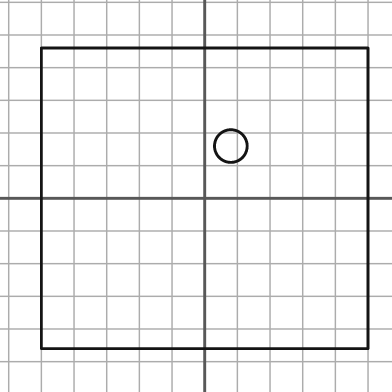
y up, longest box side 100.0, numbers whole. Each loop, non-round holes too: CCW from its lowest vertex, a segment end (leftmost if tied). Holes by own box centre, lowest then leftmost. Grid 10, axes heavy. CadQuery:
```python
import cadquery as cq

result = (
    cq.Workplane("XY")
    .moveTo(-50.0, -46.0)
    .lineTo(50.0, -46.0)
    .lineTo(50.0, 46.0)
    .lineTo(-50.0, 46.0)
    .close()
    .moveTo(8.0, 16.0)
    .circle(5.0)
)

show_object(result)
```